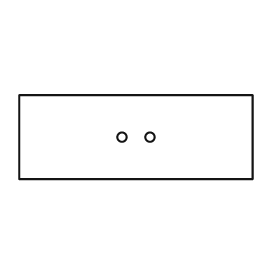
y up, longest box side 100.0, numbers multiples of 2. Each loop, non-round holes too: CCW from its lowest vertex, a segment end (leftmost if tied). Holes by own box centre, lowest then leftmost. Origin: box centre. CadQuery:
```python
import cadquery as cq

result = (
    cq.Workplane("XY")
    .moveTo(-50.0, -18.0)
    .lineTo(50.0, -18.0)
    .lineTo(50.0, 18.0)
    .lineTo(-50.0, 18.0)
    .close()
    .moveTo(-6.0, 0.0)
    .circle(2.0)
    .moveTo(6.0, 0.0)
    .circle(2.0)
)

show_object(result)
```